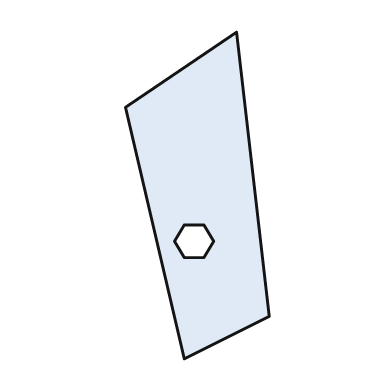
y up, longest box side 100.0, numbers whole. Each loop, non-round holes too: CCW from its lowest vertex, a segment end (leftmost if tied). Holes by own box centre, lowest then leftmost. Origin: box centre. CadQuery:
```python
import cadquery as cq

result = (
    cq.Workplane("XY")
    .moveTo(-4.0, -50.0)
    .lineTo(22.0, -37.0)
    .lineTo(12.0, 50.0)
    .lineTo(-22.0, 27.0)
    .close()
    .moveTo(-4.0, -19.0)
    .lineTo(2.0, -19.0)
    .lineTo(5.0, -14.0)
    .lineTo(2.0, -9.0)
    .lineTo(-4.0, -9.0)
    .lineTo(-7.0, -14.0)
    .close()
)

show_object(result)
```